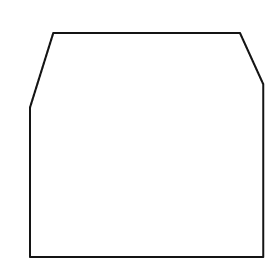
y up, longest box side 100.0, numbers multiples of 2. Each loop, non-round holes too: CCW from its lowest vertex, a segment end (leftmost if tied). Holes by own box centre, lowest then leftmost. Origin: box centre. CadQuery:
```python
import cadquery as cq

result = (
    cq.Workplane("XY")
    .moveTo(-50.0, -48.0)
    .lineTo(50.0, -48.0)
    .lineTo(50.0, 26.0)
    .lineTo(40.0, 48.0)
    .lineTo(-40.0, 48.0)
    .lineTo(-50.0, 16.0)
    .close()
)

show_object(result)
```